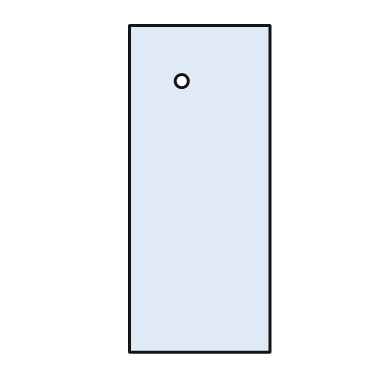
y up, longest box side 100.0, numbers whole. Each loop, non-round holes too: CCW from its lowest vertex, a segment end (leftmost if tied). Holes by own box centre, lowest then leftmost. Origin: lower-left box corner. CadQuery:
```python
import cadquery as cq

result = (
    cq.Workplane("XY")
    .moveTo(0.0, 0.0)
    .lineTo(43.0, 0.0)
    .lineTo(43.0, 100.0)
    .lineTo(0.0, 100.0)
    .close()
    .moveTo(16.0, 83.0)
    .circle(2.0)
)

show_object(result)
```